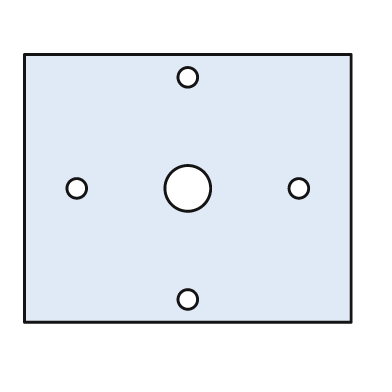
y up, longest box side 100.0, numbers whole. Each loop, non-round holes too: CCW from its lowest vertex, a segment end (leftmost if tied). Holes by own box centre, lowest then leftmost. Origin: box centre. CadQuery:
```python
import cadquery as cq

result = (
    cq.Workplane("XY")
    .moveTo(-50.0, -41.0)
    .lineTo(50.0, -41.0)
    .lineTo(50.0, 41.0)
    .lineTo(-50.0, 41.0)
    .close()
    .moveTo(0.0, -34.0)
    .circle(3.0)
    .moveTo(-34.0, 0.0)
    .circle(3.0)
    .moveTo(0.0, 0.0)
    .circle(7.0)
    .moveTo(34.0, 0.0)
    .circle(3.0)
    .moveTo(0.0, 34.0)
    .circle(3.0)
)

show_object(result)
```